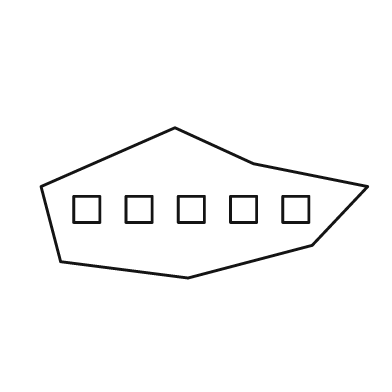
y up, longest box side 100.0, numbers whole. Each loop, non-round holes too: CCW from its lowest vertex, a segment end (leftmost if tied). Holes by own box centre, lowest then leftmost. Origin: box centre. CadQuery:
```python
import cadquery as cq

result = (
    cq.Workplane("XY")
    .moveTo(-5.0, -23.0)
    .lineTo(33.0, -13.0)
    .lineTo(50.0, 5.0)
    .lineTo(15.0, 12.0)
    .lineTo(-9.0, 23.0)
    .lineTo(-50.0, 5.0)
    .lineTo(-44.0, -18.0)
    .close()
    .moveTo(-40.0, -6.0)
    .lineTo(-32.0, -6.0)
    .lineTo(-32.0, 2.0)
    .lineTo(-40.0, 2.0)
    .close()
    .moveTo(-24.0, -6.0)
    .lineTo(-16.0, -6.0)
    .lineTo(-16.0, 2.0)
    .lineTo(-24.0, 2.0)
    .close()
    .moveTo(-8.0, -6.0)
    .lineTo(0.0, -6.0)
    .lineTo(0.0, 2.0)
    .lineTo(-8.0, 2.0)
    .close()
    .moveTo(8.0, -6.0)
    .lineTo(16.0, -6.0)
    .lineTo(16.0, 2.0)
    .lineTo(8.0, 2.0)
    .close()
    .moveTo(24.0, -6.0)
    .lineTo(32.0, -6.0)
    .lineTo(32.0, 2.0)
    .lineTo(24.0, 2.0)
    .close()
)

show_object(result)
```